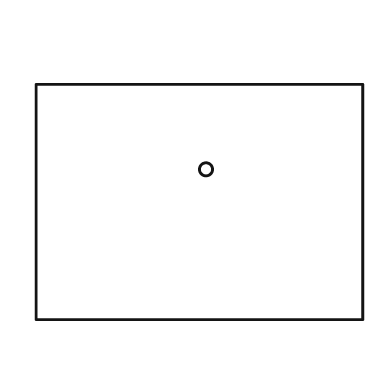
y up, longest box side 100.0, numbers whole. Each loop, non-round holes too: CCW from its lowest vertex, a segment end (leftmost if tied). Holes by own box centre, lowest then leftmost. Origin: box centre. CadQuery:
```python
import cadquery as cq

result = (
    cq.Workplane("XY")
    .moveTo(-50.0, -36.0)
    .lineTo(50.0, -36.0)
    .lineTo(50.0, 36.0)
    .lineTo(-50.0, 36.0)
    .close()
    .moveTo(2.0, 10.0)
    .circle(2.0)
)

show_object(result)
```